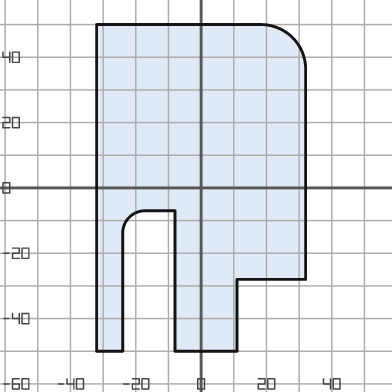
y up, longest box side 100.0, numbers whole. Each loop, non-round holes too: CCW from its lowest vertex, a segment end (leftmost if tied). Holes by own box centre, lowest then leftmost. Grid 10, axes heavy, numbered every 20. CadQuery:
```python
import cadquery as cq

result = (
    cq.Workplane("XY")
    .moveTo(-32.0, -50.0)
    .lineTo(-24.0, -50.0)
    .lineTo(-24.0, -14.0)
    .threePointArc((-22.0, -9.0), (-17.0, -7.0))
    .lineTo(-8.0, -7.0)
    .lineTo(-8.0, -50.0)
    .lineTo(11.0, -50.0)
    .lineTo(11.0, -28.0)
    .lineTo(32.0, -28.0)
    .lineTo(32.0, 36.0)
    .threePointArc((28.0, 46.0), (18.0, 50.0))
    .lineTo(-32.0, 50.0)
    .close()
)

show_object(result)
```